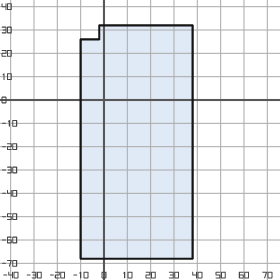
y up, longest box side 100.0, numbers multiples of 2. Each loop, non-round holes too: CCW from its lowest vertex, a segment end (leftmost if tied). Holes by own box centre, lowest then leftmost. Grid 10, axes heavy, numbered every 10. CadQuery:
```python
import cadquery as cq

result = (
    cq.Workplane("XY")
    .moveTo(-10.0, -68.0)
    .lineTo(38.0, -68.0)
    .lineTo(38.0, 32.0)
    .lineTo(-2.0, 32.0)
    .lineTo(-2.0, 26.0)
    .lineTo(-10.0, 26.0)
    .close()
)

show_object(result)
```